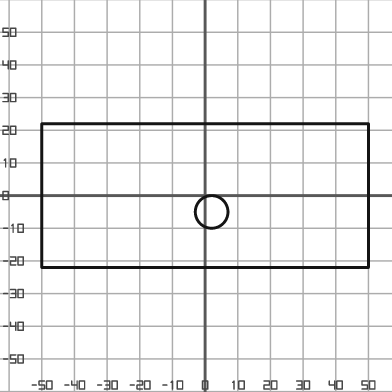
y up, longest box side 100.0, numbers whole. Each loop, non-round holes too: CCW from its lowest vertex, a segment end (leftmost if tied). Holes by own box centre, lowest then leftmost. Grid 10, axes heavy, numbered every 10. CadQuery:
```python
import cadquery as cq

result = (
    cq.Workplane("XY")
    .moveTo(-50.0, -22.0)
    .lineTo(50.0, -22.0)
    .lineTo(50.0, 22.0)
    .lineTo(-50.0, 22.0)
    .close()
    .moveTo(2.0, -5.0)
    .circle(5.0)
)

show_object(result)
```